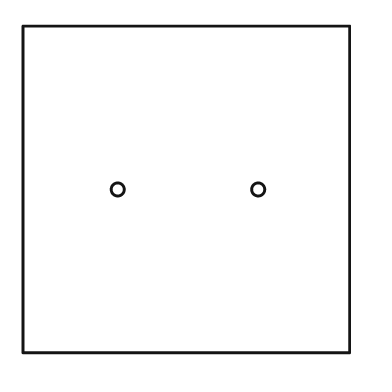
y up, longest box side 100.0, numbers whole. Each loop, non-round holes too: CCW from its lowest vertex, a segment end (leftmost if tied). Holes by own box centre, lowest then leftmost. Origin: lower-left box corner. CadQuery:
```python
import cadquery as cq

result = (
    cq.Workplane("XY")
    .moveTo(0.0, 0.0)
    .lineTo(100.0, 0.0)
    .lineTo(100.0, 100.0)
    .lineTo(0.0, 100.0)
    .close()
    .moveTo(29.0, 50.0)
    .circle(2.0)
    .moveTo(72.0, 50.0)
    .circle(2.0)
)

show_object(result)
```